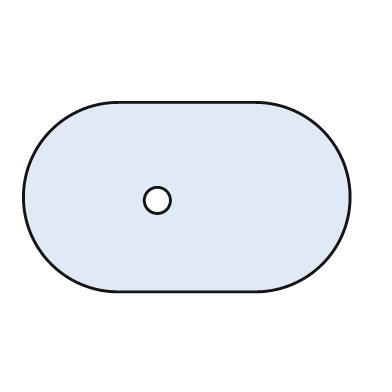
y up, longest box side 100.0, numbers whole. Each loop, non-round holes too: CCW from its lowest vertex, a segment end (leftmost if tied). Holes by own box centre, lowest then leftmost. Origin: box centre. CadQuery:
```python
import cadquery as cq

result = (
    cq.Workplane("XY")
    .moveTo(-21.0, -29.0)
    .lineTo(21.0, -29.0)
    .threePointArc((50.0, 0.0), (21.0, 29.0))
    .lineTo(-21.0, 29.0)
    .threePointArc((-50.0, 0.0), (-21.0, -29.0))
    .close()
    .moveTo(-9.0, -1.0)
    .circle(4.0)
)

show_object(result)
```